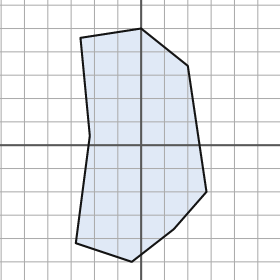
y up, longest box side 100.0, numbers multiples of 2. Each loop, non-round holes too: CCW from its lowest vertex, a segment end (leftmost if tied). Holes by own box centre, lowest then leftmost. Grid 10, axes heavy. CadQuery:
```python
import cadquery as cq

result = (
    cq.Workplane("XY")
    .moveTo(-4.0, -50.0)
    .lineTo(14.0, -36.0)
    .lineTo(28.0, -20.0)
    .lineTo(20.0, 34.0)
    .lineTo(0.0, 50.0)
    .lineTo(-26.0, 46.0)
    .lineTo(-22.0, 4.0)
    .lineTo(-28.0, -42.0)
    .close()
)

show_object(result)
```